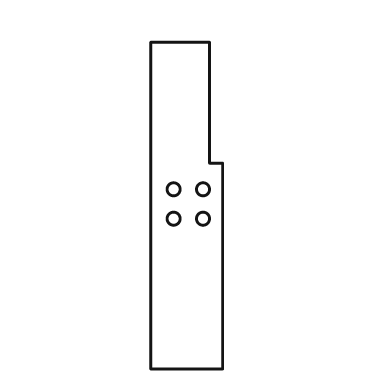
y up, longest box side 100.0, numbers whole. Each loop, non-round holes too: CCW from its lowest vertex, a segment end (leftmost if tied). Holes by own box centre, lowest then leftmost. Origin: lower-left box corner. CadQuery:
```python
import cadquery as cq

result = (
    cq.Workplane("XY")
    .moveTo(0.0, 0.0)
    .lineTo(22.0, 0.0)
    .lineTo(22.0, 63.0)
    .lineTo(18.0, 63.0)
    .lineTo(18.0, 100.0)
    .lineTo(0.0, 100.0)
    .close()
    .moveTo(7.0, 46.0)
    .circle(2.0)
    .moveTo(16.0, 46.0)
    .circle(2.0)
    .moveTo(7.0, 55.0)
    .circle(2.0)
    .moveTo(16.0, 55.0)
    .circle(2.0)
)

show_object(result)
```